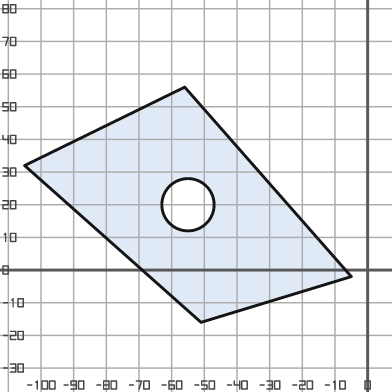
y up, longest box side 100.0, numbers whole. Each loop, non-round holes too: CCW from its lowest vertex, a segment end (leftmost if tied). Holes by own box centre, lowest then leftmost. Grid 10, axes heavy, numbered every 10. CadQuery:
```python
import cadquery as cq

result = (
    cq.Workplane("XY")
    .moveTo(-51.0, -16.0)
    .lineTo(-5.0, -2.0)
    .lineTo(-56.0, 56.0)
    .lineTo(-105.0, 32.0)
    .close()
    .moveTo(-55.0, 20.0)
    .circle(8.0)
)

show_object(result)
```